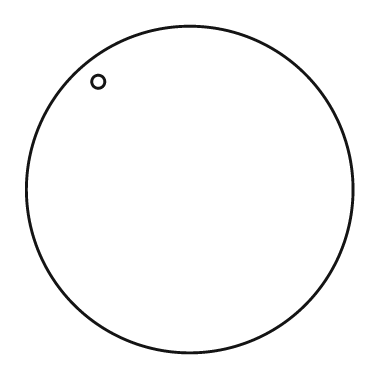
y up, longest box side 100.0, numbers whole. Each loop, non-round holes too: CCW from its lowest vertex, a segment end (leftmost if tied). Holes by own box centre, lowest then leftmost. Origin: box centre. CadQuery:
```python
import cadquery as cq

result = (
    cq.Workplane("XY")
    .moveTo(0.0, 0.0)
    .circle(50.0)
    .moveTo(-28.0, 33.0)
    .circle(2.0)
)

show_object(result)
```